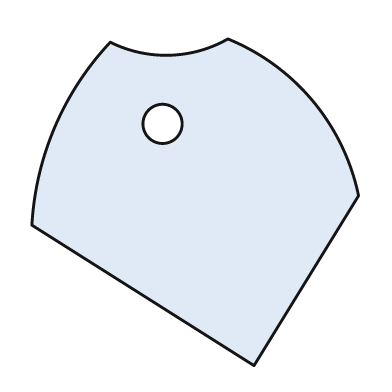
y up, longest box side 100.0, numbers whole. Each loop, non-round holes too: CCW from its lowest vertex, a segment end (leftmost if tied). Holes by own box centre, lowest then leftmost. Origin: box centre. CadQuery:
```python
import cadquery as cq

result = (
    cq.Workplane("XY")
    .moveTo(18.0, -50.0)
    .lineTo(50.0, 2.0)
    .threePointArc((36.0, 31.0), (10.0, 50.0))
    .threePointArc((-8.0, 45.0), (-26.0, 49.0))
    .threePointArc((-43.0, 23.0), (-50.0, -7.0))
    .close()
    .moveTo(-10.0, 24.0)
    .circle(6.0)
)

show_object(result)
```